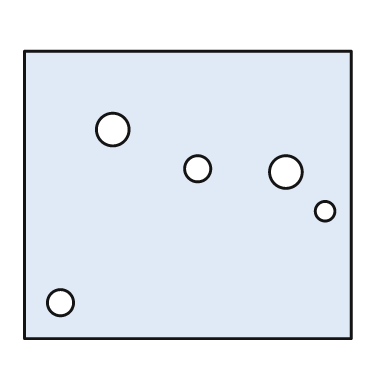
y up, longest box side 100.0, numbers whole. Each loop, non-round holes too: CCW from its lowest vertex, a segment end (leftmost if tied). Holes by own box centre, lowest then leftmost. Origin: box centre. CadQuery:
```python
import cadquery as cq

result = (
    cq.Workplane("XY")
    .moveTo(-50.0, -44.0)
    .lineTo(50.0, -44.0)
    .lineTo(50.0, 44.0)
    .lineTo(-50.0, 44.0)
    .close()
    .moveTo(-39.0, -33.0)
    .circle(4.0)
    .moveTo(42.0, -5.0)
    .circle(3.0)
    .moveTo(30.0, 7.0)
    .circle(5.0)
    .moveTo(3.0, 8.0)
    .circle(4.0)
    .moveTo(-23.0, 20.0)
    .circle(5.0)
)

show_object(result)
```